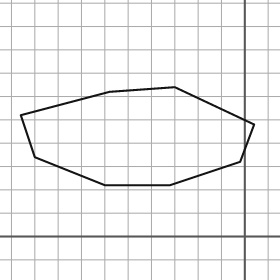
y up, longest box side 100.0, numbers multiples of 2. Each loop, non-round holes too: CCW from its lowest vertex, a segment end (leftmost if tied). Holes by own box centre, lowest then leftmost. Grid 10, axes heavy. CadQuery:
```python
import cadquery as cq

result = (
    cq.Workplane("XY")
    .moveTo(-60.0, 22.0)
    .lineTo(-32.0, 22.0)
    .lineTo(-2.0, 32.0)
    .lineTo(4.0, 48.0)
    .lineTo(-30.0, 64.0)
    .lineTo(-58.0, 62.0)
    .lineTo(-96.0, 52.0)
    .lineTo(-90.0, 34.0)
    .close()
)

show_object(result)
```